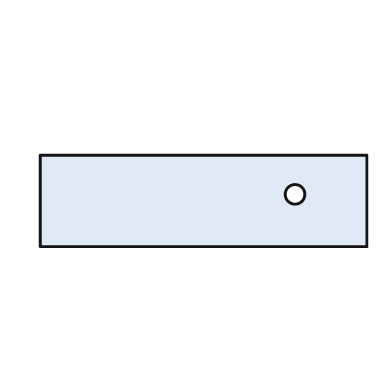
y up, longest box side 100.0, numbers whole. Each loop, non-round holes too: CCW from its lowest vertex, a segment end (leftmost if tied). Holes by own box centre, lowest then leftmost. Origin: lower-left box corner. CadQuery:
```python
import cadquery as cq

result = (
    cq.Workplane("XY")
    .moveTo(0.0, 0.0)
    .lineTo(100.0, 0.0)
    .lineTo(100.0, 28.0)
    .lineTo(0.0, 28.0)
    .close()
    .moveTo(78.0, 16.0)
    .circle(3.0)
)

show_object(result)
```